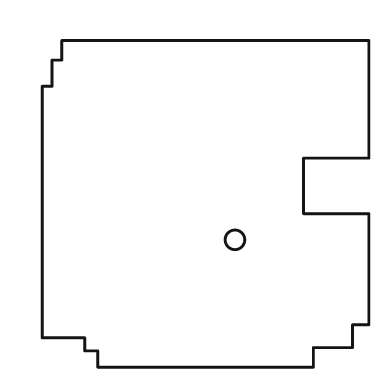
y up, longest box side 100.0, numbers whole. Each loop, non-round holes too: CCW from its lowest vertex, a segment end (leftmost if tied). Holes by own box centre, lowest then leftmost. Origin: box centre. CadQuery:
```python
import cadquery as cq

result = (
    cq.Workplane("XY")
    .moveTo(-33.0, -50.0)
    .lineTo(33.0, -50.0)
    .lineTo(33.0, -44.0)
    .lineTo(45.0, -44.0)
    .lineTo(45.0, -37.0)
    .lineTo(50.0, -37.0)
    .lineTo(50.0, -3.0)
    .lineTo(30.0, -3.0)
    .lineTo(30.0, 14.0)
    .lineTo(50.0, 14.0)
    .lineTo(50.0, 50.0)
    .lineTo(-44.0, 50.0)
    .lineTo(-44.0, 44.0)
    .lineTo(-47.0, 44.0)
    .lineTo(-47.0, 36.0)
    .lineTo(-50.0, 36.0)
    .lineTo(-50.0, -41.0)
    .lineTo(-37.0, -41.0)
    .lineTo(-37.0, -45.0)
    .lineTo(-33.0, -45.0)
    .close()
    .moveTo(9.0, -11.0)
    .circle(3.0)
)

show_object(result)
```